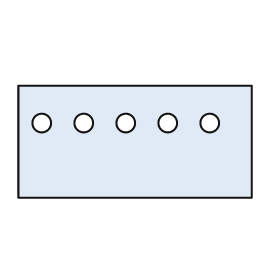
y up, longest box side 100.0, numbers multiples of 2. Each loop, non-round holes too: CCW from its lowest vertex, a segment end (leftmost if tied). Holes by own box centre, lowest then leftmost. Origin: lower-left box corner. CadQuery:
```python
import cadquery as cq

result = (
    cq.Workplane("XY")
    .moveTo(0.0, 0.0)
    .lineTo(100.0, 0.0)
    .lineTo(100.0, 48.0)
    .lineTo(0.0, 48.0)
    .close()
    .moveTo(10.0, 32.0)
    .circle(4.0)
    .moveTo(28.0, 32.0)
    .circle(4.0)
    .moveTo(46.0, 32.0)
    .circle(4.0)
    .moveTo(64.0, 32.0)
    .circle(4.0)
    .moveTo(82.0, 32.0)
    .circle(4.0)
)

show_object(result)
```